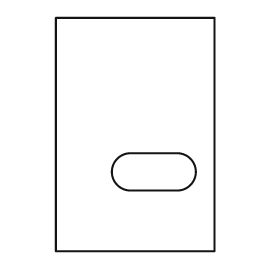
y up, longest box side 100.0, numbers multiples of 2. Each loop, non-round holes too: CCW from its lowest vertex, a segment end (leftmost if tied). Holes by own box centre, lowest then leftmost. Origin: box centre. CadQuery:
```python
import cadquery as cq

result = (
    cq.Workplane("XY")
    .moveTo(-34.0, -50.0)
    .lineTo(34.0, -50.0)
    .lineTo(34.0, 50.0)
    .lineTo(-34.0, 50.0)
    .close()
    .moveTo(-2.0, -24.0)
    .lineTo(18.0, -24.0)
    .threePointArc((26.0, -16.0), (18.0, -8.0))
    .lineTo(-2.0, -8.0)
    .threePointArc((-10.0, -16.0), (-2.0, -24.0))
    .close()
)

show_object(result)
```